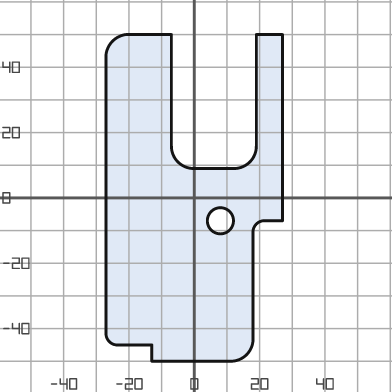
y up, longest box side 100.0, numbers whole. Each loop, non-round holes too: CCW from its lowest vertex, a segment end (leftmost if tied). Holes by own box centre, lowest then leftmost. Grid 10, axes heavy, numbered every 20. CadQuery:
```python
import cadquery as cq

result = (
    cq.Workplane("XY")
    .moveTo(-13.0, -50.0)
    .lineTo(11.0, -50.0)
    .threePointArc((16.0, -48.0), (18.0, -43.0))
    .lineTo(18.0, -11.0)
    .threePointArc((19.0, -8.0), (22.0, -7.0))
    .lineTo(27.0, -7.0)
    .lineTo(27.0, 50.0)
    .lineTo(19.0, 50.0)
    .lineTo(19.0, 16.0)
    .threePointArc((17.0, 11.0), (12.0, 9.0))
    .lineTo(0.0, 9.0)
    .threePointArc((-5.0, 11.0), (-7.0, 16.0))
    .lineTo(-7.0, 50.0)
    .lineTo(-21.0, 50.0)
    .threePointArc((-25.0, 48.0), (-27.0, 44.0))
    .lineTo(-27.0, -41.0)
    .threePointArc((-26.0, -44.0), (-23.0, -45.0))
    .lineTo(-13.0, -45.0)
    .close()
    .moveTo(8.0, -7.0)
    .circle(4.0)
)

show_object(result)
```